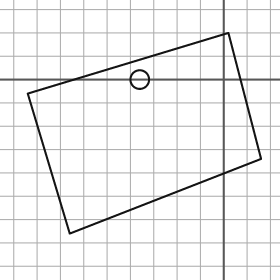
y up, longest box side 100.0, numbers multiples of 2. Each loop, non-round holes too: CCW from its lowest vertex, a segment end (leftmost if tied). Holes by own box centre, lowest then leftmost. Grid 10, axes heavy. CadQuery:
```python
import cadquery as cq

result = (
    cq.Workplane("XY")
    .moveTo(-66.0, -66.0)
    .lineTo(16.0, -34.0)
    .lineTo(2.0, 20.0)
    .lineTo(-84.0, -6.0)
    .close()
    .moveTo(-36.0, 0.0)
    .circle(4.0)
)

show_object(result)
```